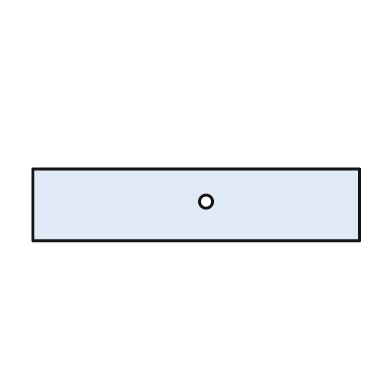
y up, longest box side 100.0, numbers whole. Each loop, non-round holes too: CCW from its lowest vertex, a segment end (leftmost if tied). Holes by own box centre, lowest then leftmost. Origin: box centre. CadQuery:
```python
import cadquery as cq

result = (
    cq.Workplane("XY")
    .moveTo(-50.0, -11.0)
    .lineTo(50.0, -11.0)
    .lineTo(50.0, 11.0)
    .lineTo(-50.0, 11.0)
    .close()
    .moveTo(3.0, 1.0)
    .circle(2.0)
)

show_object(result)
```